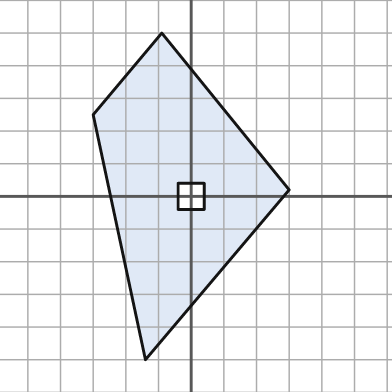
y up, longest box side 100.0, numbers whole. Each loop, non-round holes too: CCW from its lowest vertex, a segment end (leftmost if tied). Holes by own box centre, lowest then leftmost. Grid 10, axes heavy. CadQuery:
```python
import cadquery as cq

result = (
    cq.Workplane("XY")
    .moveTo(-14.0, -50.0)
    .lineTo(30.0, 2.0)
    .lineTo(-9.0, 50.0)
    .lineTo(-30.0, 25.0)
    .close()
    .moveTo(-4.0, -4.0)
    .lineTo(4.0, -4.0)
    .lineTo(4.0, 4.0)
    .lineTo(-4.0, 4.0)
    .close()
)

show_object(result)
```